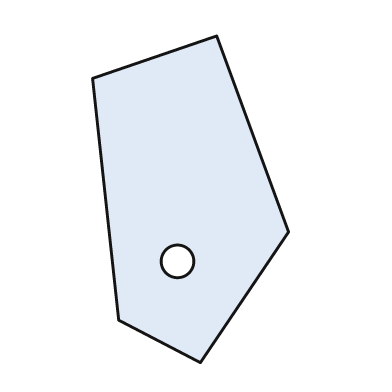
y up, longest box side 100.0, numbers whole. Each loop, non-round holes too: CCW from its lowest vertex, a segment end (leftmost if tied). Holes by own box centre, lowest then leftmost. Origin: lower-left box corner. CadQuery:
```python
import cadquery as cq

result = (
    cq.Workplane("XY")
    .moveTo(33.0, 0.0)
    .lineTo(60.0, 40.0)
    .lineTo(38.0, 100.0)
    .lineTo(0.0, 87.0)
    .lineTo(8.0, 13.0)
    .close()
    .moveTo(26.0, 31.0)
    .circle(5.0)
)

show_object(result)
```